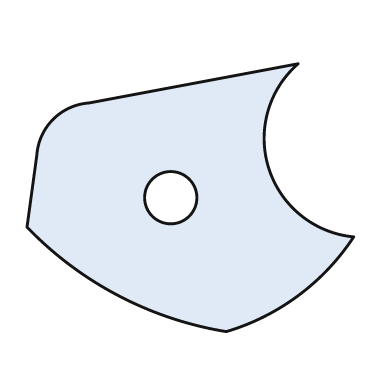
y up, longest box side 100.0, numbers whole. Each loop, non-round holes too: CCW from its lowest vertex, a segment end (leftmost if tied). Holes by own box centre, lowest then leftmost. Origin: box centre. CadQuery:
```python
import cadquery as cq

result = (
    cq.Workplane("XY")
    .moveTo(11.0, -41.0)
    .threePointArc((33.0, -30.0), (50.0, -12.0))
    .threePointArc((24.0, 9.0), (33.0, 41.0))
    .lineTo(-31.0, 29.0)
    .threePointArc((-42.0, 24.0), (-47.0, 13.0))
    .lineTo(-50.0, -9.0)
    .threePointArc((-22.0, -30.0), (11.0, -41.0))
    .close()
    .moveTo(-6.0, 0.0)
    .circle(8.0)
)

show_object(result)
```